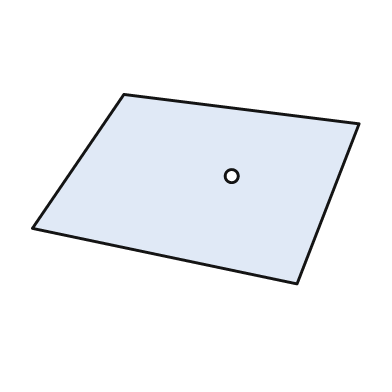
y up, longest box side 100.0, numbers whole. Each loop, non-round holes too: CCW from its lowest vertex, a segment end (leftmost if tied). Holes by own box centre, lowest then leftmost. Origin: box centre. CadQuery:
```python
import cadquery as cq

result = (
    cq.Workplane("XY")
    .moveTo(31.0, -29.0)
    .lineTo(50.0, 20.0)
    .lineTo(-22.0, 29.0)
    .lineTo(-50.0, -12.0)
    .close()
    .moveTo(11.0, 4.0)
    .circle(2.0)
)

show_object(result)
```